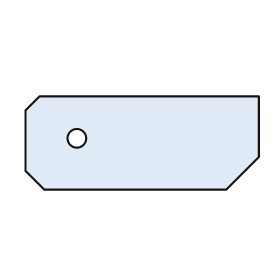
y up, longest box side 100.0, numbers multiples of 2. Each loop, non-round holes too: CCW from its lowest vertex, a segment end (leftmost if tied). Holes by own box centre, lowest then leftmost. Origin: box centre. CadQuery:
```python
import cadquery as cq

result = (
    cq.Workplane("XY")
    .moveTo(-42.0, -20.0)
    .lineTo(36.0, -20.0)
    .lineTo(50.0, -6.0)
    .lineTo(50.0, 20.0)
    .lineTo(-44.0, 20.0)
    .lineTo(-50.0, 14.0)
    .lineTo(-50.0, -12.0)
    .close()
    .moveTo(-28.0, 2.0)
    .circle(4.0)
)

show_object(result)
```